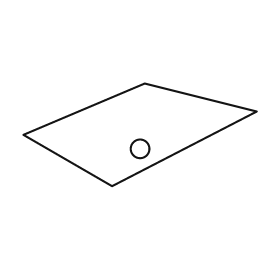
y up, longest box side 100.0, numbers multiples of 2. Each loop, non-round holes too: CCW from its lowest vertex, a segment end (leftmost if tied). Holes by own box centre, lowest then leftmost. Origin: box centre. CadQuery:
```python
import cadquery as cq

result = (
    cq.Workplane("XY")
    .moveTo(-12.0, -22.0)
    .lineTo(50.0, 10.0)
    .lineTo(2.0, 22.0)
    .lineTo(-50.0, 0.0)
    .close()
    .moveTo(0.0, -6.0)
    .circle(4.0)
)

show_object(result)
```